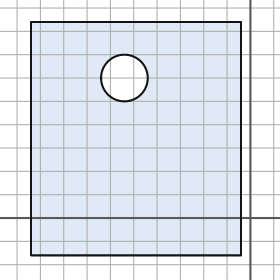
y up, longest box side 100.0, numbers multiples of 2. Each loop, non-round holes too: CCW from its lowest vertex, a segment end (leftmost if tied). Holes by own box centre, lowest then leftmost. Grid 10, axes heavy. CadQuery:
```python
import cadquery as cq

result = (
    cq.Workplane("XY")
    .moveTo(-94.0, -16.0)
    .lineTo(-4.0, -16.0)
    .lineTo(-4.0, 84.0)
    .lineTo(-94.0, 84.0)
    .close()
    .moveTo(-54.0, 60.0)
    .circle(10.0)
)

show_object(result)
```